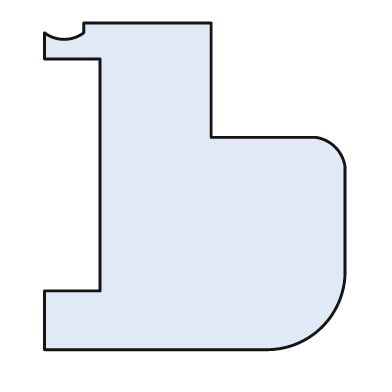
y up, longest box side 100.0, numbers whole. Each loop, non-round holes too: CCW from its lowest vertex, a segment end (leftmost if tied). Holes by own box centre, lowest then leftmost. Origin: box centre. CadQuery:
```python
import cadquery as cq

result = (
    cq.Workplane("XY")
    .moveTo(-46.0, -50.0)
    .lineTo(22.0, -50.0)
    .threePointArc((39.0, -43.0), (46.0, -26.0))
    .lineTo(46.0, 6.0)
    .threePointArc((43.0, 12.0), (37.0, 15.0))
    .lineTo(5.0, 15.0)
    .lineTo(5.0, 50.0)
    .lineTo(-34.0, 50.0)
    .lineTo(-34.0, 47.0)
    .threePointArc((-40.0, 45.0), (-46.0, 47.0))
    .lineTo(-46.0, 39.0)
    .lineTo(-29.0, 39.0)
    .lineTo(-29.0, -32.0)
    .lineTo(-46.0, -32.0)
    .close()
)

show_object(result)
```